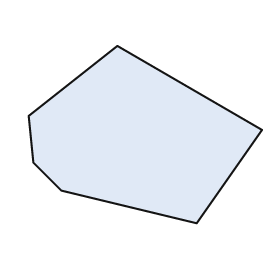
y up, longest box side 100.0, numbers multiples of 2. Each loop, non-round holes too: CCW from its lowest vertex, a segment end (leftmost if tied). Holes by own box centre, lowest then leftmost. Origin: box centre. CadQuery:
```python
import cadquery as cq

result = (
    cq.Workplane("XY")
    .moveTo(22.0, -38.0)
    .lineTo(50.0, 2.0)
    .lineTo(-12.0, 38.0)
    .lineTo(-50.0, 8.0)
    .lineTo(-48.0, -12.0)
    .lineTo(-36.0, -24.0)
    .close()
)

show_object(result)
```